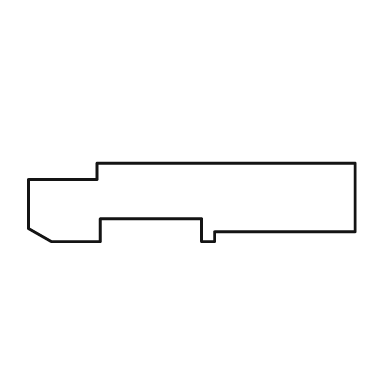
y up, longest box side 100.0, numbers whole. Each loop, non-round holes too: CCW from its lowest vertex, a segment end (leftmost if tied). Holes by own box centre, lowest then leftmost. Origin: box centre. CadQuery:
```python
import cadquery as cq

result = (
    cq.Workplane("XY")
    .moveTo(-43.0, -12.0)
    .lineTo(-28.0, -12.0)
    .lineTo(-28.0, -5.0)
    .lineTo(3.0, -5.0)
    .lineTo(3.0, -12.0)
    .lineTo(7.0, -12.0)
    .lineTo(7.0, -9.0)
    .lineTo(50.0, -9.0)
    .lineTo(50.0, 12.0)
    .lineTo(-29.0, 12.0)
    .lineTo(-29.0, 7.0)
    .lineTo(-50.0, 7.0)
    .lineTo(-50.0, -8.0)
    .close()
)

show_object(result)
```